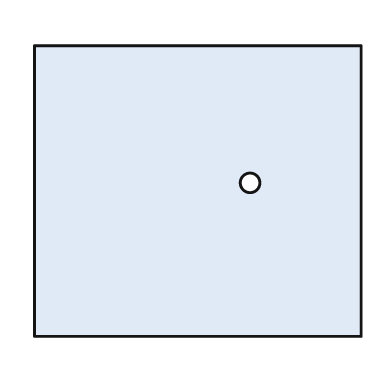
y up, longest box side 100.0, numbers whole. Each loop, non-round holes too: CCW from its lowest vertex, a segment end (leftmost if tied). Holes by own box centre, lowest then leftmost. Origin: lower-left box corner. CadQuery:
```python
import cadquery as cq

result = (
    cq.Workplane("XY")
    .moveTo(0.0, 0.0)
    .lineTo(100.0, 0.0)
    .lineTo(100.0, 89.0)
    .lineTo(0.0, 89.0)
    .close()
    .moveTo(66.0, 47.0)
    .circle(3.0)
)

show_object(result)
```